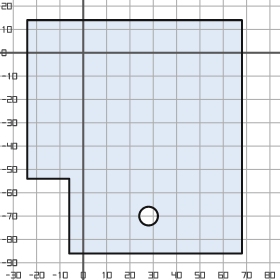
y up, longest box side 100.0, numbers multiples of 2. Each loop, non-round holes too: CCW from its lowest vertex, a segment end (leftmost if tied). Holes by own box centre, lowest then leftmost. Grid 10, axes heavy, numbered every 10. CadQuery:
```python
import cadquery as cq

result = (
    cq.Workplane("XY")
    .moveTo(-6.0, -86.0)
    .lineTo(68.0, -86.0)
    .lineTo(68.0, 14.0)
    .lineTo(-24.0, 14.0)
    .lineTo(-24.0, -54.0)
    .lineTo(-6.0, -54.0)
    .close()
    .moveTo(28.0, -70.0)
    .circle(4.0)
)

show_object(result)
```